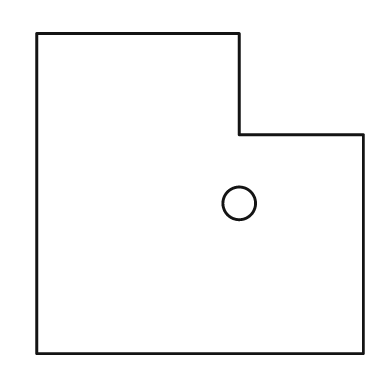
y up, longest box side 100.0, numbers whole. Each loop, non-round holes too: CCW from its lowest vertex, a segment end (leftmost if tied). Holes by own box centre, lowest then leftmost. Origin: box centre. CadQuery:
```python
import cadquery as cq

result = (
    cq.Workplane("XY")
    .moveTo(-50.0, -49.0)
    .lineTo(50.0, -49.0)
    .lineTo(50.0, 18.0)
    .lineTo(12.0, 18.0)
    .lineTo(12.0, 49.0)
    .lineTo(-50.0, 49.0)
    .close()
    .moveTo(12.0, -3.0)
    .circle(5.0)
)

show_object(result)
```